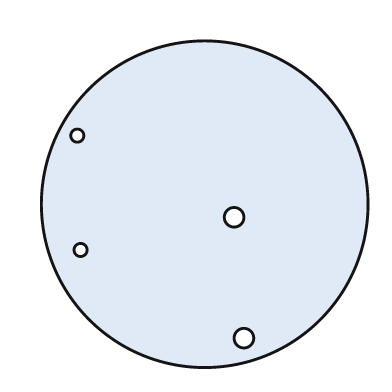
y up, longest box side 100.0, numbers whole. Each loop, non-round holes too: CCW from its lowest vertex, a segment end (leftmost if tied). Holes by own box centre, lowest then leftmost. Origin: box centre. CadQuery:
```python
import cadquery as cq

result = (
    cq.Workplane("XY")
    .moveTo(0.0, 0.0)
    .circle(50.0)
    .moveTo(12.0, -41.0)
    .circle(3.0)
    .moveTo(-38.0, -14.0)
    .circle(2.0)
    .moveTo(9.0, -4.0)
    .circle(3.0)
    .moveTo(-39.0, 21.0)
    .circle(2.0)
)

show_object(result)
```